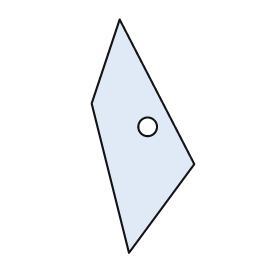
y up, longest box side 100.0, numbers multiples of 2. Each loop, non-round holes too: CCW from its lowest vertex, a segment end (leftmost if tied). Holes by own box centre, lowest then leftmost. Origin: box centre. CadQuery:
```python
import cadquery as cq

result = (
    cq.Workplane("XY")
    .moveTo(-6.0, -50.0)
    .lineTo(22.0, -12.0)
    .lineTo(-10.0, 50.0)
    .lineTo(-22.0, 14.0)
    .close()
    .moveTo(2.0, 4.0)
    .circle(4.0)
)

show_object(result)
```